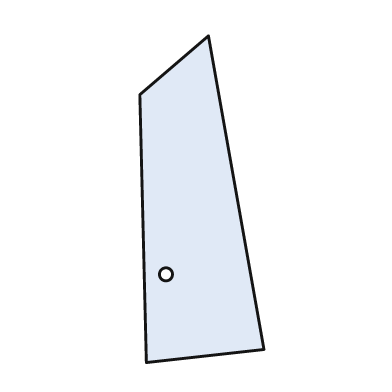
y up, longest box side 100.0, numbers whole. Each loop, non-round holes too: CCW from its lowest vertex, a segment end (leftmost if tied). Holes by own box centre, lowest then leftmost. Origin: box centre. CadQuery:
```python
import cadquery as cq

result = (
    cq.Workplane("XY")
    .moveTo(-17.0, -50.0)
    .lineTo(19.0, -46.0)
    .lineTo(2.0, 50.0)
    .lineTo(-19.0, 32.0)
    .close()
    .moveTo(-11.0, -23.0)
    .circle(2.0)
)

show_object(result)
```